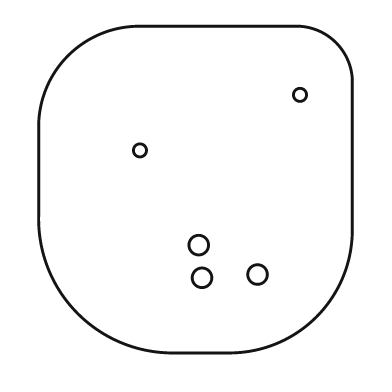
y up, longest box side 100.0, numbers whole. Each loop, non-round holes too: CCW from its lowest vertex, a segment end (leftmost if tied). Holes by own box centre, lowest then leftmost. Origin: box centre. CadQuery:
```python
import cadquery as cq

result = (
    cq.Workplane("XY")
    .moveTo(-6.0, -50.0)
    .lineTo(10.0, -50.0)
    .threePointArc((37.0, -39.0), (48.0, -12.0))
    .lineTo(48.0, 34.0)
    .threePointArc((43.0, 45.0), (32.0, 50.0))
    .lineTo(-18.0, 50.0)
    .threePointArc((-39.0, 41.0), (-48.0, 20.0))
    .lineTo(-48.0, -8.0)
    .threePointArc((-36.0, -38.0), (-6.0, -50.0))
    .close()
    .moveTo(2.0, -27.0)
    .circle(3.0)
    .moveTo(19.0, -26.0)
    .circle(3.0)
    .moveTo(1.0, -17.0)
    .circle(3.0)
    .moveTo(-17.0, 12.0)
    .circle(2.0)
    .moveTo(32.0, 29.0)
    .circle(2.0)
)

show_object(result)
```